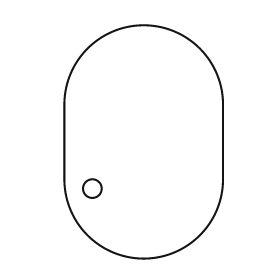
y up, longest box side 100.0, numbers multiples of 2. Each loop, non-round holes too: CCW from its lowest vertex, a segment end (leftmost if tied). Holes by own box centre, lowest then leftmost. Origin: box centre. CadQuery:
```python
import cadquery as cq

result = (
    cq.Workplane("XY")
    .moveTo(-34.0, -16.0)
    .threePointArc((0.0, -50.0), (34.0, -16.0))
    .lineTo(34.0, 16.0)
    .threePointArc((0.0, 50.0), (-34.0, 16.0))
    .close()
    .moveTo(-22.0, -20.0)
    .circle(4.0)
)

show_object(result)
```